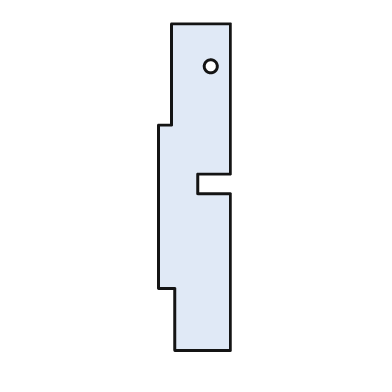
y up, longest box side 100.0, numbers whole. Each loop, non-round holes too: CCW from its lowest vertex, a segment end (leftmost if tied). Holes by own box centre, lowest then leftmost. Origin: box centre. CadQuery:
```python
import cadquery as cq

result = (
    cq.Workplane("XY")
    .moveTo(-6.0, -50.0)
    .lineTo(11.0, -50.0)
    .lineTo(11.0, -2.0)
    .lineTo(1.0, -2.0)
    .lineTo(1.0, 4.0)
    .lineTo(11.0, 4.0)
    .lineTo(11.0, 50.0)
    .lineTo(-7.0, 50.0)
    .lineTo(-7.0, 19.0)
    .lineTo(-11.0, 19.0)
    .lineTo(-11.0, -31.0)
    .lineTo(-6.0, -31.0)
    .close()
    .moveTo(5.0, 37.0)
    .circle(2.0)
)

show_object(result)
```